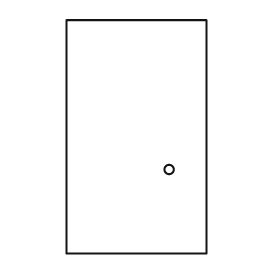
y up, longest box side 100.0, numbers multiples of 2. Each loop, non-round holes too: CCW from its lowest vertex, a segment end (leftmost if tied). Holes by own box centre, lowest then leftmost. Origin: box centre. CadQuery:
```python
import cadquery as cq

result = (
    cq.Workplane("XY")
    .moveTo(-30.0, -50.0)
    .lineTo(30.0, -50.0)
    .lineTo(30.0, 50.0)
    .lineTo(-30.0, 50.0)
    .close()
    .moveTo(14.0, -14.0)
    .circle(2.0)
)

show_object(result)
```